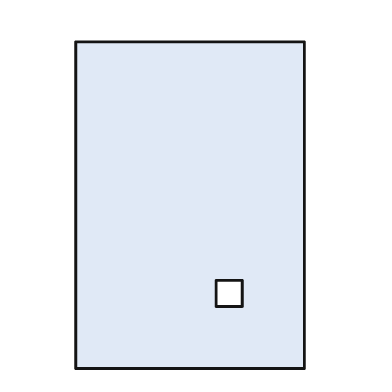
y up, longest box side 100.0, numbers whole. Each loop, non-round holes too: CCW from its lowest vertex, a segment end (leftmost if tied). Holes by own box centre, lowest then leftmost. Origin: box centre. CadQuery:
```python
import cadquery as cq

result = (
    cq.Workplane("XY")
    .moveTo(-35.0, -50.0)
    .lineTo(35.0, -50.0)
    .lineTo(35.0, 50.0)
    .lineTo(-35.0, 50.0)
    .close()
    .moveTo(8.0, -31.0)
    .lineTo(16.0, -31.0)
    .lineTo(16.0, -23.0)
    .lineTo(8.0, -23.0)
    .close()
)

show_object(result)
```